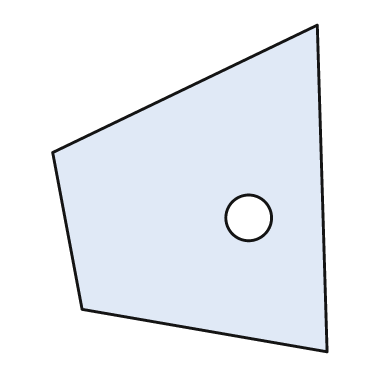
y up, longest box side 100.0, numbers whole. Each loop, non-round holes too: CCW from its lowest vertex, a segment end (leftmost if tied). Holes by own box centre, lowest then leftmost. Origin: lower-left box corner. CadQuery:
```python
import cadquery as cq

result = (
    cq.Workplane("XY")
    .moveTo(84.0, 0.0)
    .lineTo(81.0, 100.0)
    .lineTo(0.0, 61.0)
    .lineTo(9.0, 13.0)
    .close()
    .moveTo(60.0, 41.0)
    .circle(7.0)
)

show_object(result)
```